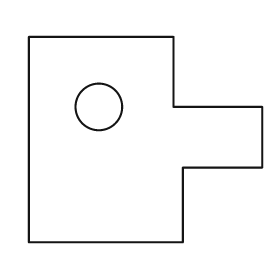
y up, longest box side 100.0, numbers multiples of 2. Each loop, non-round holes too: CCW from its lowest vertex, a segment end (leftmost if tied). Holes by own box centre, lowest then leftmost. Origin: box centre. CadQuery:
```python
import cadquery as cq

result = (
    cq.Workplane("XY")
    .moveTo(-50.0, -44.0)
    .lineTo(16.0, -44.0)
    .lineTo(16.0, -12.0)
    .lineTo(50.0, -12.0)
    .lineTo(50.0, 14.0)
    .lineTo(12.0, 14.0)
    .lineTo(12.0, 44.0)
    .lineTo(-50.0, 44.0)
    .close()
    .moveTo(-20.0, 14.0)
    .circle(10.0)
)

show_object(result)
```